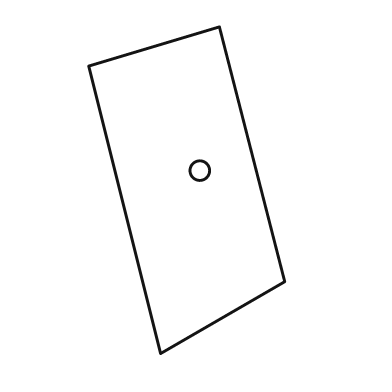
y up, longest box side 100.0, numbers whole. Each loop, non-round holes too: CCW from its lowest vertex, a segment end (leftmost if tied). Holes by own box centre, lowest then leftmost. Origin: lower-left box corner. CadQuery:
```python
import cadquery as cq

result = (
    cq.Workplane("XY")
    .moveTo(22.0, 0.0)
    .lineTo(60.0, 22.0)
    .lineTo(40.0, 100.0)
    .lineTo(0.0, 88.0)
    .close()
    .moveTo(34.0, 56.0)
    .circle(3.0)
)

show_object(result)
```